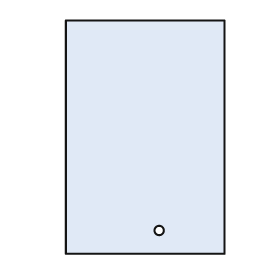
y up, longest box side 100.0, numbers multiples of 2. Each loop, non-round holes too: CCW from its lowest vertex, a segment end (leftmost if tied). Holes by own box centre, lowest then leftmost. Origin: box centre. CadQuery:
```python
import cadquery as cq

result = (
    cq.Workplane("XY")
    .moveTo(-34.0, -50.0)
    .lineTo(34.0, -50.0)
    .lineTo(34.0, 50.0)
    .lineTo(-34.0, 50.0)
    .close()
    .moveTo(6.0, -40.0)
    .circle(2.0)
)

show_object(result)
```